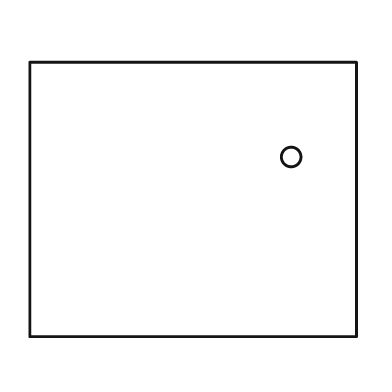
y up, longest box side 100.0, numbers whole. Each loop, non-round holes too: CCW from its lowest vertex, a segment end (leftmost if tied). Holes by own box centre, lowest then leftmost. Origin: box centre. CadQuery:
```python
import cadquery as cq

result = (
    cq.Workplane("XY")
    .moveTo(-50.0, -42.0)
    .lineTo(50.0, -42.0)
    .lineTo(50.0, 42.0)
    .lineTo(-50.0, 42.0)
    .close()
    .moveTo(30.0, 13.0)
    .circle(3.0)
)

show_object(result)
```